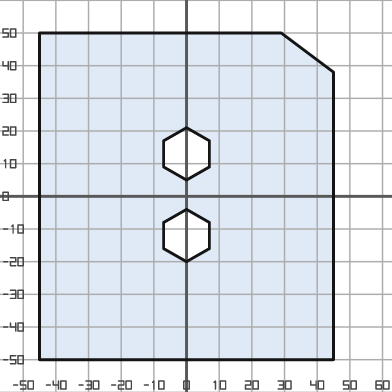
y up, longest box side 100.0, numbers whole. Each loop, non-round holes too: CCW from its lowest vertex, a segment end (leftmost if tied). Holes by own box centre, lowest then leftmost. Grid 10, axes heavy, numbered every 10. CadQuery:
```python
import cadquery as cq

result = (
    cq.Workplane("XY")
    .moveTo(-45.0, -50.0)
    .lineTo(45.0, -50.0)
    .lineTo(45.0, 38.0)
    .lineTo(29.0, 50.0)
    .lineTo(-45.0, 50.0)
    .close()
    .moveTo(0.0, -20.0)
    .lineTo(7.0, -16.0)
    .lineTo(7.0, -8.0)
    .lineTo(0.0, -4.0)
    .lineTo(-7.0, -8.0)
    .lineTo(-7.0, -16.0)
    .close()
    .moveTo(0.0, 5.0)
    .lineTo(7.0, 9.0)
    .lineTo(7.0, 17.0)
    .lineTo(0.0, 21.0)
    .lineTo(-7.0, 17.0)
    .lineTo(-7.0, 9.0)
    .close()
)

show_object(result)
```